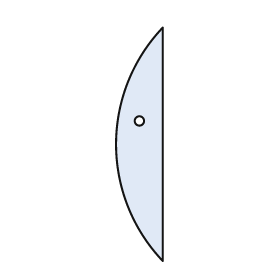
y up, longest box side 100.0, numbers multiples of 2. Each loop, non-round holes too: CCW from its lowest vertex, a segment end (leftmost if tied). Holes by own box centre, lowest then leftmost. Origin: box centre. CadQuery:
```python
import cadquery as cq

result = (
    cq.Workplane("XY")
    .moveTo(10.0, -50.0)
    .lineTo(10.0, 50.0)
    .threePointArc((-10.0, 0.0), (10.0, -50.0))
    .close()
    .moveTo(0.0, 10.0)
    .circle(2.0)
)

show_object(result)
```